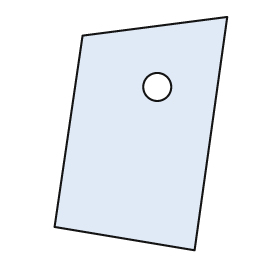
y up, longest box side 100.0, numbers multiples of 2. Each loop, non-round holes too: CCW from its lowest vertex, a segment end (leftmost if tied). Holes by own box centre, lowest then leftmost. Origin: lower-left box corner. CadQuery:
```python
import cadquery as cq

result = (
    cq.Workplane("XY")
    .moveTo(60.0, 0.0)
    .lineTo(74.0, 100.0)
    .lineTo(12.0, 92.0)
    .lineTo(0.0, 10.0)
    .close()
    .moveTo(44.0, 70.0)
    .circle(6.0)
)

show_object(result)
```